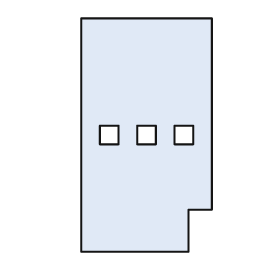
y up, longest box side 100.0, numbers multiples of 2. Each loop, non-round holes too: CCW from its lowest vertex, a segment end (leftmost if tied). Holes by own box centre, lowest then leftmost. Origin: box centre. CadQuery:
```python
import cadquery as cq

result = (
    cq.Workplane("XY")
    .moveTo(-28.0, -50.0)
    .lineTo(18.0, -50.0)
    .lineTo(18.0, -32.0)
    .lineTo(28.0, -32.0)
    .lineTo(28.0, 50.0)
    .lineTo(-28.0, 50.0)
    .close()
    .moveTo(-20.0, -4.0)
    .lineTo(-12.0, -4.0)
    .lineTo(-12.0, 4.0)
    .lineTo(-20.0, 4.0)
    .close()
    .moveTo(-4.0, -4.0)
    .lineTo(4.0, -4.0)
    .lineTo(4.0, 4.0)
    .lineTo(-4.0, 4.0)
    .close()
    .moveTo(12.0, -4.0)
    .lineTo(20.0, -4.0)
    .lineTo(20.0, 4.0)
    .lineTo(12.0, 4.0)
    .close()
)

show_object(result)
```